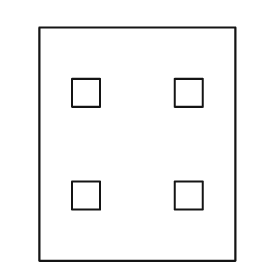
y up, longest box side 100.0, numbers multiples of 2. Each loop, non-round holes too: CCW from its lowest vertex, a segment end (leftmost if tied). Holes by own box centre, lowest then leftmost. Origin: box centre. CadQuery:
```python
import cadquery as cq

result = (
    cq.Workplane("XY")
    .moveTo(-42.0, -50.0)
    .lineTo(42.0, -50.0)
    .lineTo(42.0, 50.0)
    .lineTo(-42.0, 50.0)
    .close()
    .moveTo(-28.0, -28.0)
    .lineTo(-16.0, -28.0)
    .lineTo(-16.0, -16.0)
    .lineTo(-28.0, -16.0)
    .close()
    .moveTo(16.0, -28.0)
    .lineTo(28.0, -28.0)
    .lineTo(28.0, -16.0)
    .lineTo(16.0, -16.0)
    .close()
    .moveTo(-28.0, 16.0)
    .lineTo(-16.0, 16.0)
    .lineTo(-16.0, 28.0)
    .lineTo(-28.0, 28.0)
    .close()
    .moveTo(16.0, 16.0)
    .lineTo(28.0, 16.0)
    .lineTo(28.0, 28.0)
    .lineTo(16.0, 28.0)
    .close()
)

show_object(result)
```